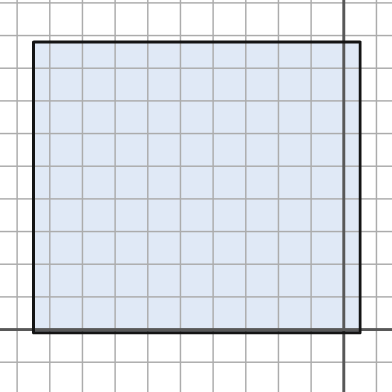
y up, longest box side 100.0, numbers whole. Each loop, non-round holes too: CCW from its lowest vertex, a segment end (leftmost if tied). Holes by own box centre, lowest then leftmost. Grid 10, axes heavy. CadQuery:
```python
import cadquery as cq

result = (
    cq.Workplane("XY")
    .moveTo(-95.0, -1.0)
    .lineTo(5.0, -1.0)
    .lineTo(5.0, 88.0)
    .lineTo(-95.0, 88.0)
    .close()
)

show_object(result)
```